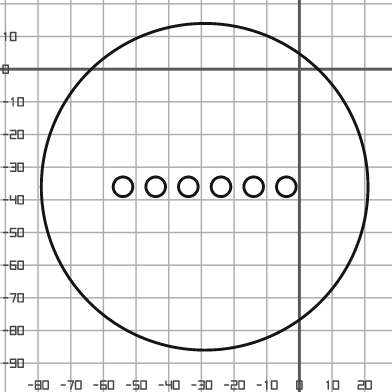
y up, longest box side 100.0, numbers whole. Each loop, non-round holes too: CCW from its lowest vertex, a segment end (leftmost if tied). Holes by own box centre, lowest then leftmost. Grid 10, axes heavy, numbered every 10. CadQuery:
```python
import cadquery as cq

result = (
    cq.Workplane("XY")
    .moveTo(-29.0, -36.0)
    .circle(50.0)
    .moveTo(-54.0, -36.0)
    .circle(3.0)
    .moveTo(-44.0, -36.0)
    .circle(3.0)
    .moveTo(-34.0, -36.0)
    .circle(3.0)
    .moveTo(-24.0, -36.0)
    .circle(3.0)
    .moveTo(-14.0, -36.0)
    .circle(3.0)
    .moveTo(-4.0, -36.0)
    .circle(3.0)
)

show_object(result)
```